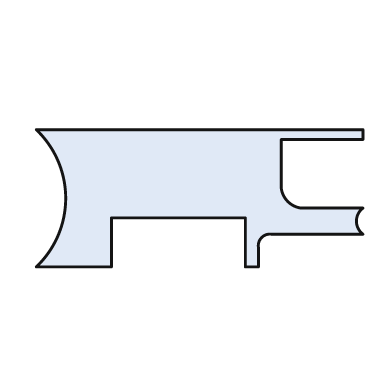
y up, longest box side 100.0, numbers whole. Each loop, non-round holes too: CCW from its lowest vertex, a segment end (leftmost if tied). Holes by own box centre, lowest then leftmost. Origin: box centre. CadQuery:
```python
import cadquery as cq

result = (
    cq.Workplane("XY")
    .moveTo(-50.0, -21.0)
    .lineTo(-27.0, -21.0)
    .lineTo(-27.0, -6.0)
    .lineTo(14.0, -6.0)
    .lineTo(14.0, -21.0)
    .lineTo(18.0, -21.0)
    .lineTo(18.0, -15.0)
    .threePointArc((19.0, -12.0), (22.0, -11.0))
    .lineTo(50.0, -11.0)
    .threePointArc((48.0, -7.0), (50.0, -3.0))
    .lineTo(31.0, -3.0)
    .threePointArc((27.0, -1.0), (25.0, 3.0))
    .lineTo(25.0, 18.0)
    .lineTo(50.0, 18.0)
    .lineTo(50.0, 21.0)
    .lineTo(-50.0, 21.0)
    .threePointArc((-41.0, 0.0), (-50.0, -21.0))
    .close()
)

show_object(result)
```